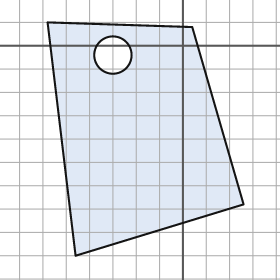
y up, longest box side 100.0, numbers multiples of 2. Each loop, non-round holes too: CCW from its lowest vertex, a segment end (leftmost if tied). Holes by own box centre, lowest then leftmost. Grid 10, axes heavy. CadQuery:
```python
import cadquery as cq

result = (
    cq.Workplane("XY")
    .moveTo(-46.0, -90.0)
    .lineTo(26.0, -68.0)
    .lineTo(4.0, 8.0)
    .lineTo(-58.0, 10.0)
    .close()
    .moveTo(-30.0, -4.0)
    .circle(8.0)
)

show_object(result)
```